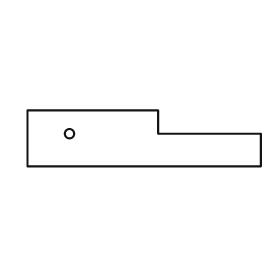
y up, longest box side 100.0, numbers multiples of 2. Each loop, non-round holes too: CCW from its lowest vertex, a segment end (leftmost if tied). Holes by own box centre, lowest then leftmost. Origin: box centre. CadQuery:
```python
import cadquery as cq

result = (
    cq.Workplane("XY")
    .moveTo(-50.0, -12.0)
    .lineTo(50.0, -12.0)
    .lineTo(50.0, 2.0)
    .lineTo(6.0, 2.0)
    .lineTo(6.0, 12.0)
    .lineTo(-50.0, 12.0)
    .close()
    .moveTo(-32.0, 2.0)
    .circle(2.0)
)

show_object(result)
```